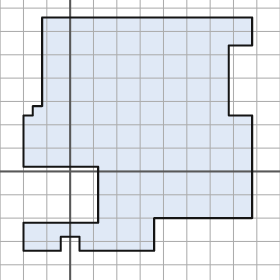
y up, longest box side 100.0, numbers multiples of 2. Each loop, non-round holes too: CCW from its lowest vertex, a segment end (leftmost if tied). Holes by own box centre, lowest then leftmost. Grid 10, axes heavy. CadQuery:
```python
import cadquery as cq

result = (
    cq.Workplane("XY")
    .moveTo(-20.0, -34.0)
    .lineTo(-4.0, -34.0)
    .lineTo(-4.0, -28.0)
    .lineTo(4.0, -28.0)
    .lineTo(4.0, -34.0)
    .lineTo(36.0, -34.0)
    .lineTo(36.0, -20.0)
    .lineTo(78.0, -20.0)
    .lineTo(78.0, 24.0)
    .lineTo(68.0, 24.0)
    .lineTo(68.0, 54.0)
    .lineTo(78.0, 54.0)
    .lineTo(78.0, 66.0)
    .lineTo(-12.0, 66.0)
    .lineTo(-12.0, 28.0)
    .lineTo(-16.0, 28.0)
    .lineTo(-16.0, 24.0)
    .lineTo(-20.0, 24.0)
    .lineTo(-20.0, 2.0)
    .lineTo(12.0, 2.0)
    .lineTo(12.0, -22.0)
    .lineTo(-20.0, -22.0)
    .close()
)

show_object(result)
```